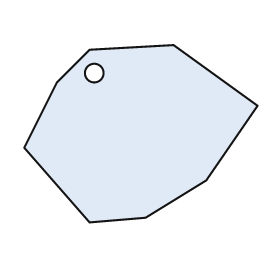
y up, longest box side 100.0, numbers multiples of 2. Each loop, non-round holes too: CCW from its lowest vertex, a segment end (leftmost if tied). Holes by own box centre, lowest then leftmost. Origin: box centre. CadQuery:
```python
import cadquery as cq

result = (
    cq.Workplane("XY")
    .moveTo(-22.0, -38.0)
    .lineTo(2.0, -36.0)
    .lineTo(28.0, -20.0)
    .lineTo(50.0, 12.0)
    .lineTo(14.0, 38.0)
    .lineTo(-22.0, 36.0)
    .lineTo(-36.0, 22.0)
    .lineTo(-50.0, -6.0)
    .close()
    .moveTo(-20.0, 26.0)
    .circle(4.0)
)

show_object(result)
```